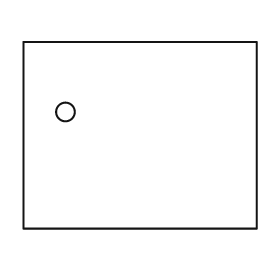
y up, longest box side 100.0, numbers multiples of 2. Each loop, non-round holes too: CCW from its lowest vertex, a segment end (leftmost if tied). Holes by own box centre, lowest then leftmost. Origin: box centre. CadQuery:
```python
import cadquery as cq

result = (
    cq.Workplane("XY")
    .moveTo(-50.0, -40.0)
    .lineTo(50.0, -40.0)
    .lineTo(50.0, 40.0)
    .lineTo(-50.0, 40.0)
    .close()
    .moveTo(-32.0, 10.0)
    .circle(4.0)
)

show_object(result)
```